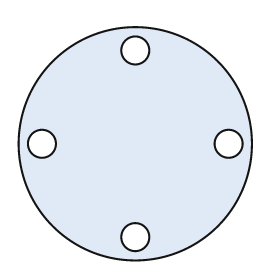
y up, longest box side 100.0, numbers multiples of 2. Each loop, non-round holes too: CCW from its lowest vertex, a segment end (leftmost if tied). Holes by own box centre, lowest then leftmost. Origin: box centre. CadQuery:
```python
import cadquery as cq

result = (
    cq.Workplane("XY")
    .moveTo(0.0, 0.0)
    .circle(50.0)
    .moveTo(0.0, -40.0)
    .circle(6.0)
    .moveTo(-40.0, 0.0)
    .circle(6.0)
    .moveTo(40.0, 0.0)
    .circle(6.0)
    .moveTo(0.0, 40.0)
    .circle(6.0)
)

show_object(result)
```